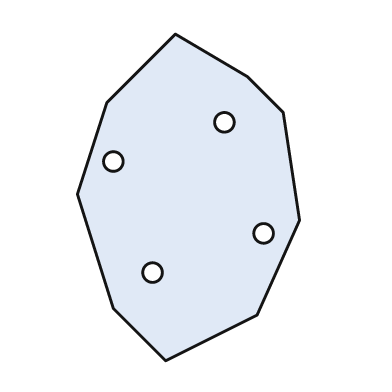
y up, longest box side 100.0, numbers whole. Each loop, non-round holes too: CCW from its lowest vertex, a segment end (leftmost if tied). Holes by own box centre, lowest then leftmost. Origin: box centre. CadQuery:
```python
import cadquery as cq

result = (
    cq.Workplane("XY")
    .moveTo(-7.0, -50.0)
    .lineTo(21.0, -36.0)
    .lineTo(34.0, -7.0)
    .lineTo(29.0, 26.0)
    .lineTo(18.0, 37.0)
    .lineTo(-4.0, 50.0)
    .lineTo(-25.0, 29.0)
    .lineTo(-34.0, 1.0)
    .lineTo(-23.0, -34.0)
    .close()
    .moveTo(-11.0, -23.0)
    .circle(3.0)
    .moveTo(23.0, -11.0)
    .circle(3.0)
    .moveTo(-23.0, 11.0)
    .circle(3.0)
    .moveTo(11.0, 23.0)
    .circle(3.0)
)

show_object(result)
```